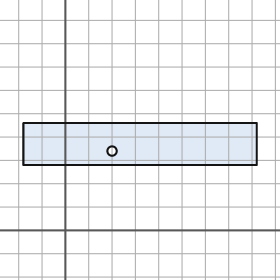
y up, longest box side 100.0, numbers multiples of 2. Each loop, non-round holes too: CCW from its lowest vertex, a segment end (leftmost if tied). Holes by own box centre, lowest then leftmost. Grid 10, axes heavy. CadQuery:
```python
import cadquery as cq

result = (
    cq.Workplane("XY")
    .moveTo(-18.0, 28.0)
    .lineTo(82.0, 28.0)
    .lineTo(82.0, 46.0)
    .lineTo(-18.0, 46.0)
    .close()
    .moveTo(20.0, 34.0)
    .circle(2.0)
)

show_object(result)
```